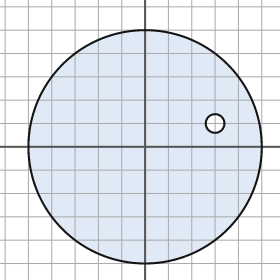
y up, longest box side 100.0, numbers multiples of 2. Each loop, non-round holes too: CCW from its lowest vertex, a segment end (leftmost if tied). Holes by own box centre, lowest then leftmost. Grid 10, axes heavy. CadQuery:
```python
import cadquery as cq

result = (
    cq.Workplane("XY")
    .moveTo(0.0, 0.0)
    .circle(50.0)
    .moveTo(30.0, 10.0)
    .circle(4.0)
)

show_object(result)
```